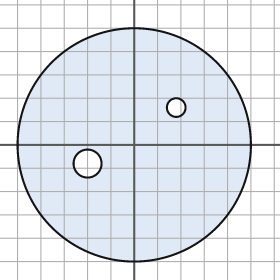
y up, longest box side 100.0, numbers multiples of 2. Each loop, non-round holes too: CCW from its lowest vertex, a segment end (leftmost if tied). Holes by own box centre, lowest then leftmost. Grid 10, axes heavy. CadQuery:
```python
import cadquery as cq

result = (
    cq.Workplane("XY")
    .moveTo(0.0, 0.0)
    .circle(50.0)
    .moveTo(-20.0, -8.0)
    .circle(6.0)
    .moveTo(18.0, 16.0)
    .circle(4.0)
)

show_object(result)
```